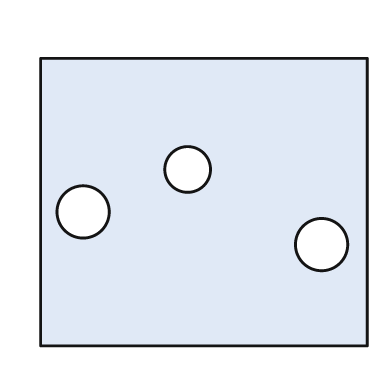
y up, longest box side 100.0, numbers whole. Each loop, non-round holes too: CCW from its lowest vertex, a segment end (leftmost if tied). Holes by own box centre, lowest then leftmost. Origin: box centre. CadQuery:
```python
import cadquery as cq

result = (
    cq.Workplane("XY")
    .moveTo(-50.0, -44.0)
    .lineTo(50.0, -44.0)
    .lineTo(50.0, 44.0)
    .lineTo(-50.0, 44.0)
    .close()
    .moveTo(36.0, -13.0)
    .circle(8.0)
    .moveTo(-37.0, -3.0)
    .circle(8.0)
    .moveTo(-5.0, 10.0)
    .circle(7.0)
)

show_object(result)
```